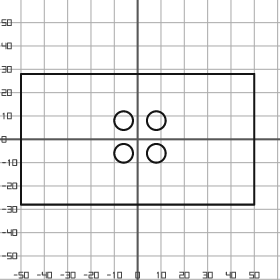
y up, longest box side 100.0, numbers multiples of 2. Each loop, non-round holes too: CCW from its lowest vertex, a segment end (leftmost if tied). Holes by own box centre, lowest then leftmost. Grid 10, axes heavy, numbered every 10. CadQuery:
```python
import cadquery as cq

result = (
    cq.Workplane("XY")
    .moveTo(-50.0, -28.0)
    .lineTo(50.0, -28.0)
    .lineTo(50.0, 28.0)
    .lineTo(-50.0, 28.0)
    .close()
    .moveTo(-6.0, -6.0)
    .circle(4.0)
    .moveTo(8.0, -6.0)
    .circle(4.0)
    .moveTo(-6.0, 8.0)
    .circle(4.0)
    .moveTo(8.0, 8.0)
    .circle(4.0)
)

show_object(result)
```